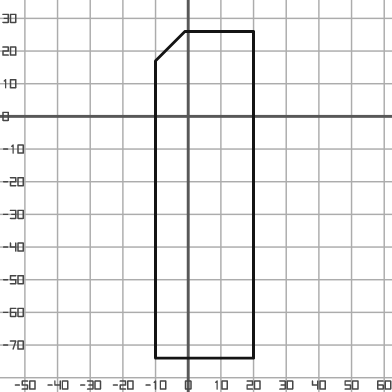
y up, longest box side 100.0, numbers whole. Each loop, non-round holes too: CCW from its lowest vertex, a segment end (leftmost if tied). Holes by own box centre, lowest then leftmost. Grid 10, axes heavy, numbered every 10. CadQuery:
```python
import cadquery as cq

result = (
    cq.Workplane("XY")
    .moveTo(-10.0, -74.0)
    .lineTo(20.0, -74.0)
    .lineTo(20.0, 26.0)
    .lineTo(-1.0, 26.0)
    .lineTo(-10.0, 17.0)
    .close()
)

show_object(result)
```